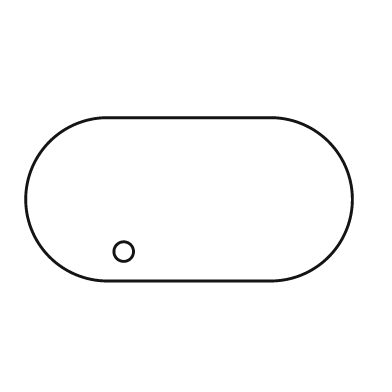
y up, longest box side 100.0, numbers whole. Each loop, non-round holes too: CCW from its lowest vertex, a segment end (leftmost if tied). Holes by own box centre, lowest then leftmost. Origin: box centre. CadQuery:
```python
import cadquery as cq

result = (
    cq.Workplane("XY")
    .moveTo(-25.0, -25.0)
    .lineTo(25.0, -25.0)
    .threePointArc((50.0, 0.0), (25.0, 25.0))
    .lineTo(-25.0, 25.0)
    .threePointArc((-50.0, 0.0), (-25.0, -25.0))
    .close()
    .moveTo(-20.0, -16.0)
    .circle(3.0)
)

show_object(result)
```